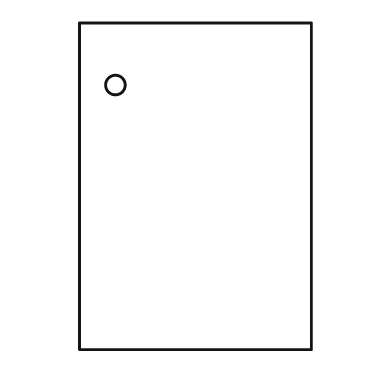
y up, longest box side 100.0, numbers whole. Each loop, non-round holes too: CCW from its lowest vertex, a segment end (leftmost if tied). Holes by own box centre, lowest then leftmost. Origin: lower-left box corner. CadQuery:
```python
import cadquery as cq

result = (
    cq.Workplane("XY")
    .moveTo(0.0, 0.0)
    .lineTo(71.0, 0.0)
    .lineTo(71.0, 100.0)
    .lineTo(0.0, 100.0)
    .close()
    .moveTo(11.0, 81.0)
    .circle(3.0)
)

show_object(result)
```